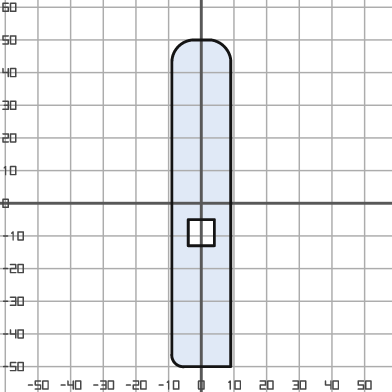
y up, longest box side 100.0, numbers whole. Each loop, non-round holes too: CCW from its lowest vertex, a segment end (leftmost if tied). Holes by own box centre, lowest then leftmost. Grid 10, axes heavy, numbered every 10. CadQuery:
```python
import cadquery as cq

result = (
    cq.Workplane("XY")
    .moveTo(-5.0, -50.0)
    .lineTo(9.0, -50.0)
    .lineTo(9.0, 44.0)
    .threePointArc((7.0, 48.0), (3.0, 50.0))
    .lineTo(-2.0, 50.0)
    .threePointArc((-7.0, 48.0), (-9.0, 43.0))
    .lineTo(-9.0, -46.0)
    .threePointArc((-8.0, -49.0), (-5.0, -50.0))
    .close()
    .moveTo(-4.0, -13.0)
    .lineTo(4.0, -13.0)
    .lineTo(4.0, -5.0)
    .lineTo(-4.0, -5.0)
    .close()
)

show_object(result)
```